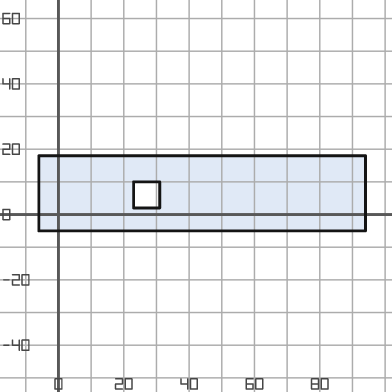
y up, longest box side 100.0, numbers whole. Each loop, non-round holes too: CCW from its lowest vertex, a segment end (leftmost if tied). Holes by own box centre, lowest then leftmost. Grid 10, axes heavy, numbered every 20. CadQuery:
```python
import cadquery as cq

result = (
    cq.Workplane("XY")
    .moveTo(-6.0, -5.0)
    .lineTo(94.0, -5.0)
    .lineTo(94.0, 18.0)
    .lineTo(-6.0, 18.0)
    .close()
    .moveTo(23.0, 2.0)
    .lineTo(31.0, 2.0)
    .lineTo(31.0, 10.0)
    .lineTo(23.0, 10.0)
    .close()
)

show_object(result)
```